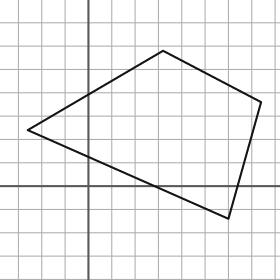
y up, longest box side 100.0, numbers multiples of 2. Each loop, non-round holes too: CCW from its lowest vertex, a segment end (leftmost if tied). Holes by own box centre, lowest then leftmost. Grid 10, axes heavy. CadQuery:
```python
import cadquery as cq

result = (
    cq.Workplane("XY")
    .moveTo(60.0, -14.0)
    .lineTo(74.0, 36.0)
    .lineTo(32.0, 58.0)
    .lineTo(-26.0, 24.0)
    .close()
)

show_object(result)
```